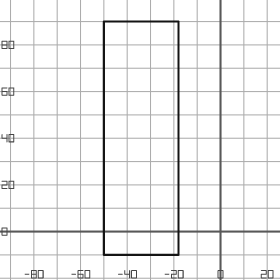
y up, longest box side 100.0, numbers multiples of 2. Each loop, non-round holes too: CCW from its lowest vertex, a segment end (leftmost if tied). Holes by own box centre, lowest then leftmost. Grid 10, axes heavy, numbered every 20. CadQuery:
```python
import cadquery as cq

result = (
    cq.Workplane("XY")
    .moveTo(-50.0, -10.0)
    .lineTo(-18.0, -10.0)
    .lineTo(-18.0, 90.0)
    .lineTo(-50.0, 90.0)
    .close()
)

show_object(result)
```